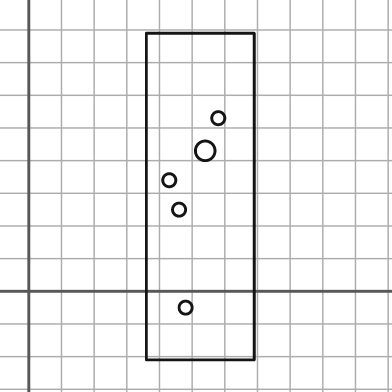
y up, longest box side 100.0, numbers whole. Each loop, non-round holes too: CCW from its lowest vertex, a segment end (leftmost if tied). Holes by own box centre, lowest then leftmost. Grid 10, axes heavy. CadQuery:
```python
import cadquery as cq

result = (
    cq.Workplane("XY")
    .moveTo(36.0, -21.0)
    .lineTo(69.0, -21.0)
    .lineTo(69.0, 79.0)
    .lineTo(36.0, 79.0)
    .close()
    .moveTo(48.0, -5.0)
    .circle(2.0)
    .moveTo(46.0, 25.0)
    .circle(2.0)
    .moveTo(43.0, 34.0)
    .circle(2.0)
    .moveTo(54.0, 43.0)
    .circle(3.0)
    .moveTo(58.0, 53.0)
    .circle(2.0)
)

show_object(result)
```